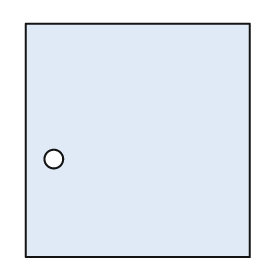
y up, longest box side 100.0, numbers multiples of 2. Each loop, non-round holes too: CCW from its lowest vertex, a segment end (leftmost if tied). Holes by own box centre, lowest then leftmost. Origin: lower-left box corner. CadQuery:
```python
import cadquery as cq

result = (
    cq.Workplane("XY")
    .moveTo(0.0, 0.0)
    .lineTo(96.0, 0.0)
    .lineTo(96.0, 100.0)
    .lineTo(0.0, 100.0)
    .close()
    .moveTo(12.0, 42.0)
    .circle(4.0)
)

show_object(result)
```